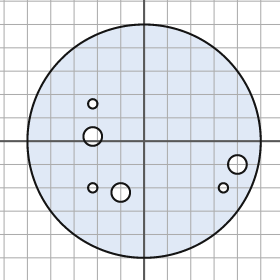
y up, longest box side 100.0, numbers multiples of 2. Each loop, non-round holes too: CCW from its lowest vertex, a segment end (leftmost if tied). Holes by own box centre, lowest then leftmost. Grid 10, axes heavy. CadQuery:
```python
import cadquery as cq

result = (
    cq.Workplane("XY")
    .moveTo(0.0, 0.0)
    .circle(50.0)
    .moveTo(-10.0, -22.0)
    .circle(4.0)
    .moveTo(-22.0, -20.0)
    .circle(2.0)
    .moveTo(34.0, -20.0)
    .circle(2.0)
    .moveTo(40.0, -10.0)
    .circle(4.0)
    .moveTo(-22.0, 2.0)
    .circle(4.0)
    .moveTo(-22.0, 16.0)
    .circle(2.0)
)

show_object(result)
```